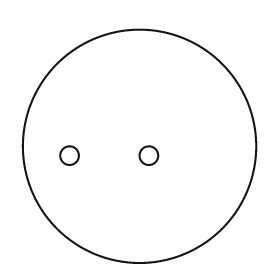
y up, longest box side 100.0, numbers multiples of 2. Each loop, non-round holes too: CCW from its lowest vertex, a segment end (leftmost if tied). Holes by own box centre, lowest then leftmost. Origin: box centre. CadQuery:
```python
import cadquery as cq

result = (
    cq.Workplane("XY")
    .moveTo(0.0, 0.0)
    .circle(50.0)
    .moveTo(-30.0, -4.0)
    .circle(4.0)
    .moveTo(4.0, -4.0)
    .circle(4.0)
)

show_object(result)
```